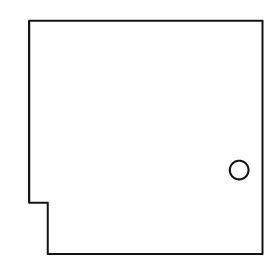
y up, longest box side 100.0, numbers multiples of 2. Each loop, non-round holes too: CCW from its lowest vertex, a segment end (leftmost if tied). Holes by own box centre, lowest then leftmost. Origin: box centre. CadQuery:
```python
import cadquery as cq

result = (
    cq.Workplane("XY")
    .moveTo(-42.0, -50.0)
    .lineTo(50.0, -50.0)
    .lineTo(50.0, 50.0)
    .lineTo(-50.0, 50.0)
    .lineTo(-50.0, -28.0)
    .lineTo(-42.0, -28.0)
    .close()
    .moveTo(40.0, -14.0)
    .circle(4.0)
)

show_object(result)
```